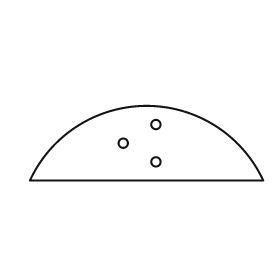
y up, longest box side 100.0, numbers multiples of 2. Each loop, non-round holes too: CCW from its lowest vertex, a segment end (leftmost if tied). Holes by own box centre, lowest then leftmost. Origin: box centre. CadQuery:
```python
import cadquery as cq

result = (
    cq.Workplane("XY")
    .moveTo(-50.0, -16.0)
    .lineTo(50.0, -16.0)
    .threePointArc((0.0, 16.0), (-50.0, -16.0))
    .close()
    .moveTo(4.0, -8.0)
    .circle(2.0)
    .moveTo(-10.0, 0.0)
    .circle(2.0)
    .moveTo(4.0, 8.0)
    .circle(2.0)
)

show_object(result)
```